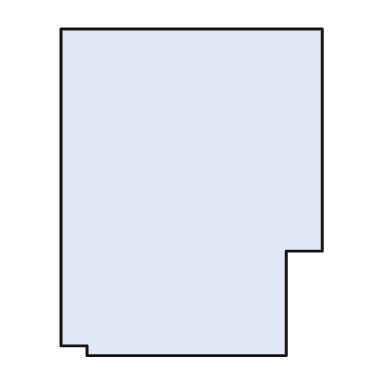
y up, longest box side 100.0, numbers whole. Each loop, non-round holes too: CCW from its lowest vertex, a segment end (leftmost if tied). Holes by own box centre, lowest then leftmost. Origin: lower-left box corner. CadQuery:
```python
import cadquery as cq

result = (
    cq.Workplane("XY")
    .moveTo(8.0, 0.0)
    .lineTo(69.0, 0.0)
    .lineTo(69.0, 32.0)
    .lineTo(80.0, 32.0)
    .lineTo(80.0, 100.0)
    .lineTo(0.0, 100.0)
    .lineTo(0.0, 3.0)
    .lineTo(8.0, 3.0)
    .close()
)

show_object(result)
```